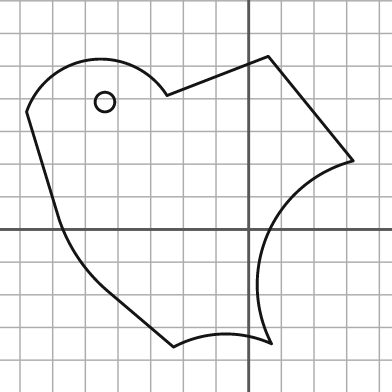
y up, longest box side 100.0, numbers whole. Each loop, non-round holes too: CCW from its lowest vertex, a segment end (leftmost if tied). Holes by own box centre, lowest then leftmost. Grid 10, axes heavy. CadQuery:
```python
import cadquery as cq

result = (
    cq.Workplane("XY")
    .moveTo(-23.0, -36.0)
    .threePointArc((-8.0, -32.0), (7.0, -35.0))
    .threePointArc((6.0, -1.0), (32.0, 21.0))
    .lineTo(6.0, 53.0)
    .lineTo(-25.0, 41.0)
    .threePointArc((-48.0, 52.0), (-68.0, 36.0))
    .lineTo(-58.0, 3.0)
    .threePointArc((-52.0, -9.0), (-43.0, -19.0))
    .close()
    .moveTo(-44.0, 39.0)
    .circle(3.0)
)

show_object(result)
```